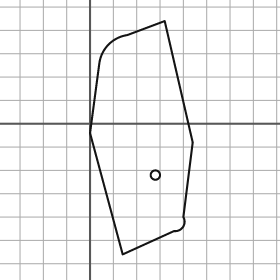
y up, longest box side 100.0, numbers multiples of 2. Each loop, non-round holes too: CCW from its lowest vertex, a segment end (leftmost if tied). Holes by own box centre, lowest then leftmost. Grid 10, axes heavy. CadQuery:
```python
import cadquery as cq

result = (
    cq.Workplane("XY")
    .moveTo(14.0, -56.0)
    .lineTo(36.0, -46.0)
    .threePointArc((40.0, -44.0), (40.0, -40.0))
    .lineTo(44.0, -8.0)
    .lineTo(32.0, 44.0)
    .lineTo(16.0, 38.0)
    .threePointArc((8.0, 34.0), (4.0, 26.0))
    .lineTo(0.0, -4.0)
    .close()
    .moveTo(28.0, -22.0)
    .circle(2.0)
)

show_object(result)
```